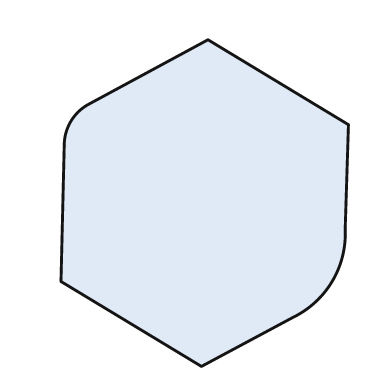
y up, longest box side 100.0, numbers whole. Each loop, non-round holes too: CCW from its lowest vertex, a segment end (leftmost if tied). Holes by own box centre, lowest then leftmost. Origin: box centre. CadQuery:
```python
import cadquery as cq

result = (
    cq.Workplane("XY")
    .moveTo(-1.0, -50.0)
    .lineTo(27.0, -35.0)
    .threePointArc((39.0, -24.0), (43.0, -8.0))
    .lineTo(44.0, 24.0)
    .lineTo(1.0, 50.0)
    .lineTo(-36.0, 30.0)
    .threePointArc((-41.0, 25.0), (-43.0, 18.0))
    .lineTo(-44.0, -24.0)
    .close()
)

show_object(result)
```